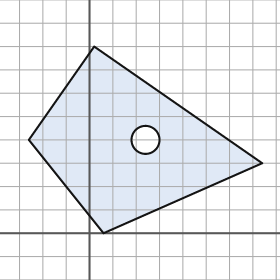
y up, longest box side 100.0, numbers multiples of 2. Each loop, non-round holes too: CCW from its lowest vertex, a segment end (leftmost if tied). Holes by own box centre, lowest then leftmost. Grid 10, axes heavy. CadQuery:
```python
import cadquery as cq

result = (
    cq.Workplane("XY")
    .moveTo(6.0, 0.0)
    .lineTo(74.0, 30.0)
    .lineTo(2.0, 80.0)
    .lineTo(-26.0, 40.0)
    .close()
    .moveTo(24.0, 40.0)
    .circle(6.0)
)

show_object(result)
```